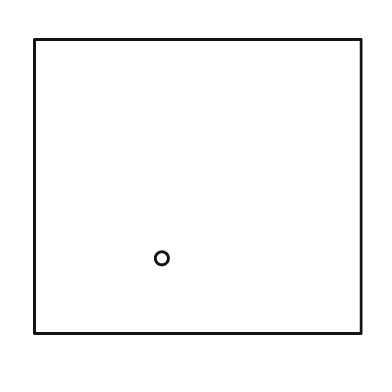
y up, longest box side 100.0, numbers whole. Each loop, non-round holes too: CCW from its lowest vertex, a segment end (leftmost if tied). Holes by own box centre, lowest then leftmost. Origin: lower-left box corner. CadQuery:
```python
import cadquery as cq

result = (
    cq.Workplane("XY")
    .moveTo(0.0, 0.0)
    .lineTo(100.0, 0.0)
    .lineTo(100.0, 90.0)
    .lineTo(0.0, 90.0)
    .close()
    .moveTo(39.0, 23.0)
    .circle(2.0)
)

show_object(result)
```